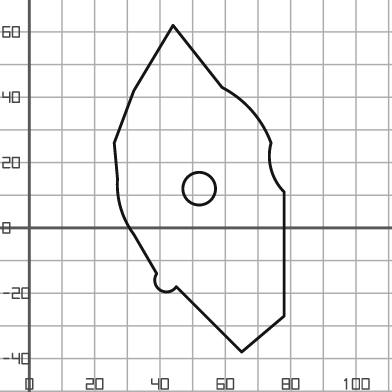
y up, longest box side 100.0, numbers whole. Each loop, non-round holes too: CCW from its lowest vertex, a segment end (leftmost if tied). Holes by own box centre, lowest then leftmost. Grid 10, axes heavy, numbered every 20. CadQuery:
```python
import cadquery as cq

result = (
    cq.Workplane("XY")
    .moveTo(65.0, -38.0)
    .lineTo(78.0, -27.0)
    .lineTo(78.0, 11.0)
    .threePointArc((74.0, 18.0), (74.0, 26.0))
    .threePointArc((68.0, 36.0), (59.0, 43.0))
    .lineTo(44.0, 62.0)
    .lineTo(32.0, 42.0)
    .lineTo(26.0, 26.0)
    .lineTo(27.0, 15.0)
    .threePointArc((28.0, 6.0), (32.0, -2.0))
    .lineTo(39.0, -14.0)
    .threePointArc((40.0, -19.0), (45.0, -18.0))
    .close()
    .moveTo(52.0, 12.0)
    .circle(5.0)
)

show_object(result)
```